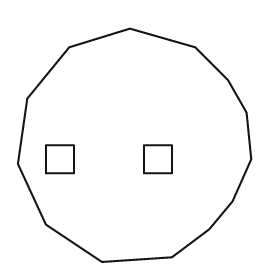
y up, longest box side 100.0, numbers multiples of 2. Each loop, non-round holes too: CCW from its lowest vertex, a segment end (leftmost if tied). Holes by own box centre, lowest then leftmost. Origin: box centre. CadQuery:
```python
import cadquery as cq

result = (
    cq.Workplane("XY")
    .moveTo(-14.0, -50.0)
    .lineTo(16.0, -48.0)
    .lineTo(32.0, -36.0)
    .lineTo(42.0, -24.0)
    .lineTo(50.0, -6.0)
    .lineTo(48.0, 14.0)
    .lineTo(40.0, 28.0)
    .lineTo(26.0, 42.0)
    .lineTo(-2.0, 50.0)
    .lineTo(-28.0, 42.0)
    .lineTo(-46.0, 20.0)
    .lineTo(-50.0, -8.0)
    .lineTo(-38.0, -34.0)
    .close()
    .moveTo(-38.0, -12.0)
    .lineTo(-26.0, -12.0)
    .lineTo(-26.0, 0.0)
    .lineTo(-38.0, 0.0)
    .close()
    .moveTo(4.0, -12.0)
    .lineTo(16.0, -12.0)
    .lineTo(16.0, 0.0)
    .lineTo(4.0, 0.0)
    .close()
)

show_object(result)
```